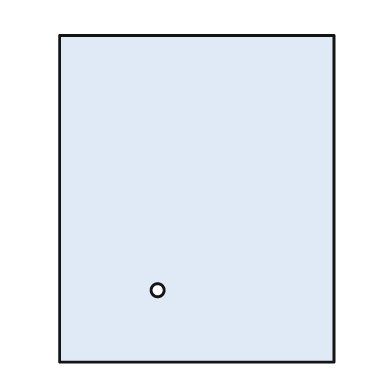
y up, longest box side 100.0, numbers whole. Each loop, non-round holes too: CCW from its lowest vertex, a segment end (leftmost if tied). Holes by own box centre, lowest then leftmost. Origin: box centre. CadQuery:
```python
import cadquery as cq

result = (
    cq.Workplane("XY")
    .moveTo(-42.0, -50.0)
    .lineTo(42.0, -50.0)
    .lineTo(42.0, 50.0)
    .lineTo(-42.0, 50.0)
    .close()
    .moveTo(-12.0, -28.0)
    .circle(2.0)
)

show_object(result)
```